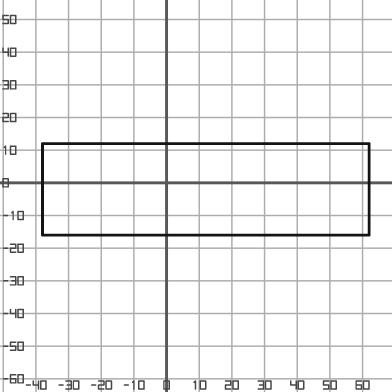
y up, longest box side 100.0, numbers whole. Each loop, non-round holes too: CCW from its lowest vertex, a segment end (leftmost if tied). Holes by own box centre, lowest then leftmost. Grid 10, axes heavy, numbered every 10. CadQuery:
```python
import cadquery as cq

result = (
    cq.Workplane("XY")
    .moveTo(-38.0, -16.0)
    .lineTo(62.0, -16.0)
    .lineTo(62.0, 12.0)
    .lineTo(-38.0, 12.0)
    .close()
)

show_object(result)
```